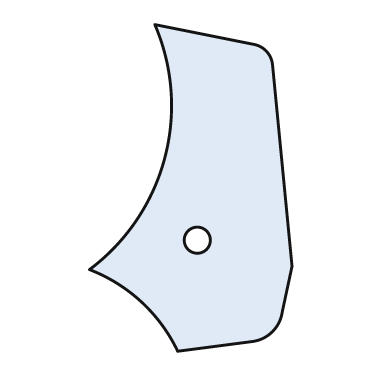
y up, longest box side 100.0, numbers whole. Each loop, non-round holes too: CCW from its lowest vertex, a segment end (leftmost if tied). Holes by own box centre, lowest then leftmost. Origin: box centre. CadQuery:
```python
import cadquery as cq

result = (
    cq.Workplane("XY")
    .moveTo(-4.0, -50.0)
    .lineTo(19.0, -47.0)
    .threePointArc((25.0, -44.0), (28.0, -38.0))
    .lineTo(31.0, -24.0)
    .lineTo(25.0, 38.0)
    .threePointArc((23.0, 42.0), (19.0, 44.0))
    .lineTo(-11.0, 50.0)
    .threePointArc((-8.0, 9.0), (-31.0, -25.0))
    .threePointArc((-15.0, -35.0), (-4.0, -50.0))
    .close()
    .moveTo(2.0, -16.0)
    .circle(4.0)
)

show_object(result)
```